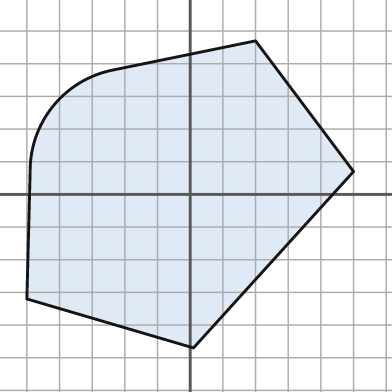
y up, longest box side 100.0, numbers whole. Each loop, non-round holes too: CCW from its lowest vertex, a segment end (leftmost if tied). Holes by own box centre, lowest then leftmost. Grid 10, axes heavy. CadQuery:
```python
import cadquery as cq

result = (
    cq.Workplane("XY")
    .moveTo(1.0, -47.0)
    .lineTo(50.0, 7.0)
    .lineTo(20.0, 47.0)
    .lineTo(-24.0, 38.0)
    .threePointArc((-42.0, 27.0), (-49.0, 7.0))
    .lineTo(-50.0, -32.0)
    .close()
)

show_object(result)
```